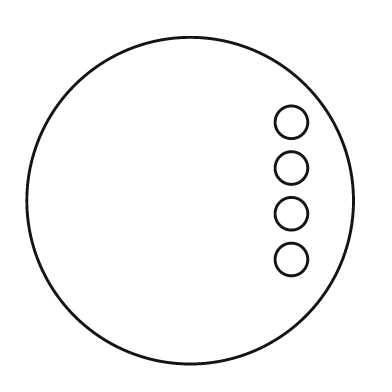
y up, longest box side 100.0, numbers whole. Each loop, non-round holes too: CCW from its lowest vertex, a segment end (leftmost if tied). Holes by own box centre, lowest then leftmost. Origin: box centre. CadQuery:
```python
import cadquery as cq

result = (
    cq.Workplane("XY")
    .moveTo(0.0, 0.0)
    .circle(50.0)
    .moveTo(31.0, -18.0)
    .circle(5.0)
    .moveTo(31.0, -4.0)
    .circle(5.0)
    .moveTo(31.0, 10.0)
    .circle(5.0)
    .moveTo(31.0, 24.0)
    .circle(5.0)
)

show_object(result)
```